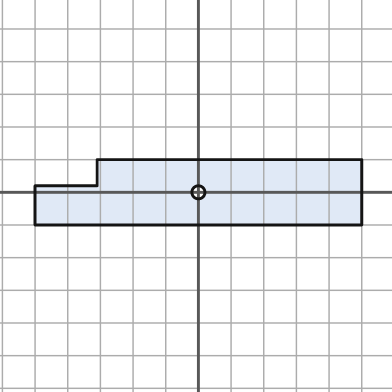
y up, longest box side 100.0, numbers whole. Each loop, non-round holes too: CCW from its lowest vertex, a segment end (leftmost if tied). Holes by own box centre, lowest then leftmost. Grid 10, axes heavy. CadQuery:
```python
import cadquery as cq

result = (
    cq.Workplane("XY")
    .moveTo(-50.0, -10.0)
    .lineTo(50.0, -10.0)
    .lineTo(50.0, 10.0)
    .lineTo(-31.0, 10.0)
    .lineTo(-31.0, 2.0)
    .lineTo(-50.0, 2.0)
    .close()
    .moveTo(0.0, 0.0)
    .circle(2.0)
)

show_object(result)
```